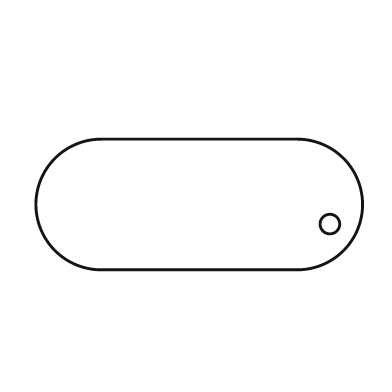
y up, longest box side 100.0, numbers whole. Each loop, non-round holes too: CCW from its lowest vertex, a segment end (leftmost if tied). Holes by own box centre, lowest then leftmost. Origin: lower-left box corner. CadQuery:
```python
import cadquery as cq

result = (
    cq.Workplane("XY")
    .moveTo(20.0, 0.0)
    .lineTo(80.0, 0.0)
    .threePointArc((100.0, 20.0), (80.0, 40.0))
    .lineTo(20.0, 40.0)
    .threePointArc((0.0, 20.0), (20.0, 0.0))
    .close()
    .moveTo(90.0, 14.0)
    .circle(3.0)
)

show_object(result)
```